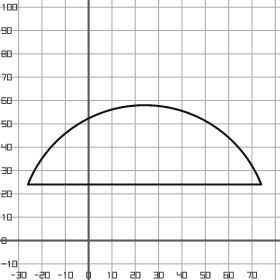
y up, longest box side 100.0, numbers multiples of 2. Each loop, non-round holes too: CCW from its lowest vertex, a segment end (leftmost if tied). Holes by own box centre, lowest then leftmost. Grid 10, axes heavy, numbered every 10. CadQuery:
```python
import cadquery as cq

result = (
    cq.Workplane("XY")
    .moveTo(-26.0, 24.0)
    .lineTo(74.0, 24.0)
    .threePointArc((24.0, 58.0), (-26.0, 24.0))
    .close()
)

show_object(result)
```